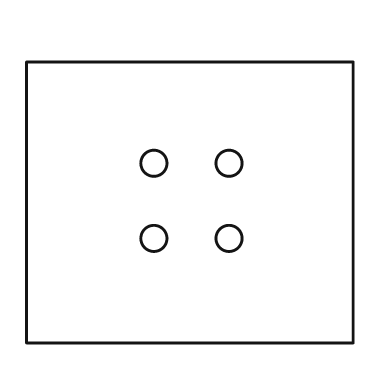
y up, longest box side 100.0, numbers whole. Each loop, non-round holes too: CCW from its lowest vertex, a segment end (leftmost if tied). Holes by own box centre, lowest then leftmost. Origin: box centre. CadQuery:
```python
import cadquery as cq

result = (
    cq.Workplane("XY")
    .moveTo(-50.0, -43.0)
    .lineTo(50.0, -43.0)
    .lineTo(50.0, 43.0)
    .lineTo(-50.0, 43.0)
    .close()
    .moveTo(-11.0, -11.0)
    .circle(4.0)
    .moveTo(12.0, -11.0)
    .circle(4.0)
    .moveTo(-11.0, 12.0)
    .circle(4.0)
    .moveTo(12.0, 12.0)
    .circle(4.0)
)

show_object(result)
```